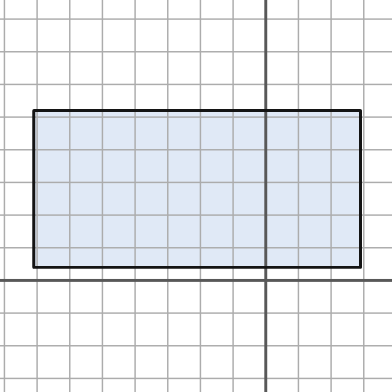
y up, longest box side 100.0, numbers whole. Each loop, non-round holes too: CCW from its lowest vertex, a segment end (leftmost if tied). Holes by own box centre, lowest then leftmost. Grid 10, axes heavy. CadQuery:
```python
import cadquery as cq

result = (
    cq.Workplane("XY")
    .moveTo(-71.0, 4.0)
    .lineTo(29.0, 4.0)
    .lineTo(29.0, 52.0)
    .lineTo(-71.0, 52.0)
    .close()
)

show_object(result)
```